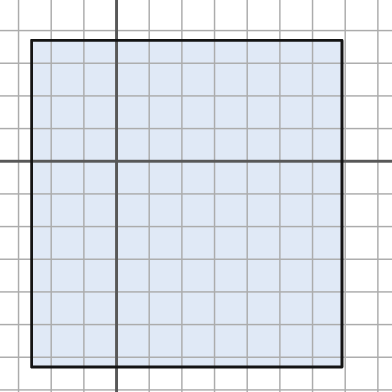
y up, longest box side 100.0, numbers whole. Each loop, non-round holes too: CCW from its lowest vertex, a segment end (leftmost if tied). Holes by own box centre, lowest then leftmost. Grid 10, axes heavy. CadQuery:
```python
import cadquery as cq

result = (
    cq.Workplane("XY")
    .moveTo(-26.0, -63.0)
    .lineTo(69.0, -63.0)
    .lineTo(69.0, 37.0)
    .lineTo(-26.0, 37.0)
    .close()
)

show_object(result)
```